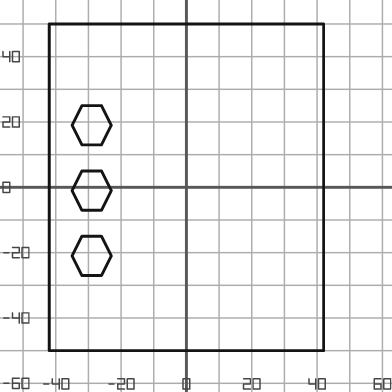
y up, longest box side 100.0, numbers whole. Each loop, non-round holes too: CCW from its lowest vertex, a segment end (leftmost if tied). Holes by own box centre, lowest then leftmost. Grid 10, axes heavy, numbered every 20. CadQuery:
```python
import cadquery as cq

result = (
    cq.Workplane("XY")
    .moveTo(-42.0, -50.0)
    .lineTo(42.0, -50.0)
    .lineTo(42.0, 50.0)
    .lineTo(-42.0, 50.0)
    .close()
    .moveTo(-32.0, -27.0)
    .lineTo(-26.0, -27.0)
    .lineTo(-23.0, -21.0)
    .lineTo(-26.0, -15.0)
    .lineTo(-32.0, -15.0)
    .lineTo(-35.0, -21.0)
    .close()
    .moveTo(-32.0, -7.0)
    .lineTo(-26.0, -7.0)
    .lineTo(-23.0, -1.0)
    .lineTo(-26.0, 5.0)
    .lineTo(-32.0, 5.0)
    .lineTo(-35.0, -1.0)
    .close()
    .moveTo(-32.0, 13.0)
    .lineTo(-26.0, 13.0)
    .lineTo(-23.0, 19.0)
    .lineTo(-26.0, 25.0)
    .lineTo(-32.0, 25.0)
    .lineTo(-35.0, 19.0)
    .close()
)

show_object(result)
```